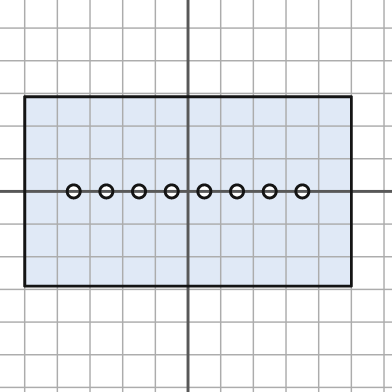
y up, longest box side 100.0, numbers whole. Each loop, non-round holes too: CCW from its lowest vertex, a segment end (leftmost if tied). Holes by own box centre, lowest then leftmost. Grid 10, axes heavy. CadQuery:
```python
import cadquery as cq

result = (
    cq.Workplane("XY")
    .moveTo(-50.0, -29.0)
    .lineTo(50.0, -29.0)
    .lineTo(50.0, 29.0)
    .lineTo(-50.0, 29.0)
    .close()
    .moveTo(-35.0, 0.0)
    .circle(2.0)
    .moveTo(-25.0, 0.0)
    .circle(2.0)
    .moveTo(-15.0, 0.0)
    .circle(2.0)
    .moveTo(-5.0, 0.0)
    .circle(2.0)
    .moveTo(5.0, 0.0)
    .circle(2.0)
    .moveTo(15.0, 0.0)
    .circle(2.0)
    .moveTo(25.0, 0.0)
    .circle(2.0)
    .moveTo(35.0, 0.0)
    .circle(2.0)
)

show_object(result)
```